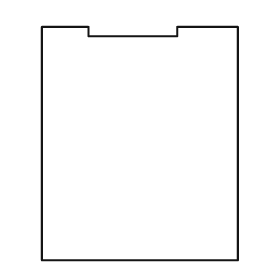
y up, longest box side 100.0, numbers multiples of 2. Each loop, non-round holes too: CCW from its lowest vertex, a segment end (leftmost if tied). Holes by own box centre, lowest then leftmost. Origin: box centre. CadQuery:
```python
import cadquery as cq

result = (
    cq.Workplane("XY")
    .moveTo(-42.0, -50.0)
    .lineTo(42.0, -50.0)
    .lineTo(42.0, 50.0)
    .lineTo(16.0, 50.0)
    .lineTo(16.0, 46.0)
    .lineTo(-22.0, 46.0)
    .lineTo(-22.0, 50.0)
    .lineTo(-42.0, 50.0)
    .close()
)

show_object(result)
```